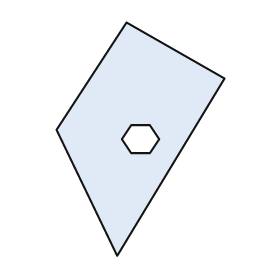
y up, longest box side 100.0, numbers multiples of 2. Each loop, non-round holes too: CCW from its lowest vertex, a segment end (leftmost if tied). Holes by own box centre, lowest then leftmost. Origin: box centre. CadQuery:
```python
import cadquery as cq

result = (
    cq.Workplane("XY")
    .moveTo(-10.0, -50.0)
    .lineTo(36.0, 26.0)
    .lineTo(-6.0, 50.0)
    .lineTo(-36.0, 4.0)
    .close()
    .moveTo(-4.0, -6.0)
    .lineTo(4.0, -6.0)
    .lineTo(8.0, 0.0)
    .lineTo(4.0, 6.0)
    .lineTo(-4.0, 6.0)
    .lineTo(-8.0, 0.0)
    .close()
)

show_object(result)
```